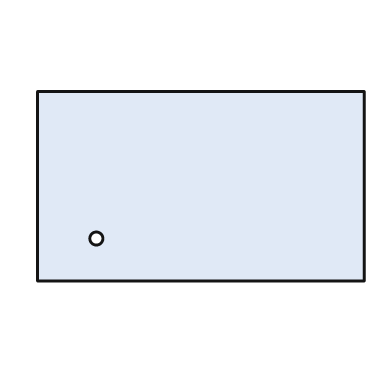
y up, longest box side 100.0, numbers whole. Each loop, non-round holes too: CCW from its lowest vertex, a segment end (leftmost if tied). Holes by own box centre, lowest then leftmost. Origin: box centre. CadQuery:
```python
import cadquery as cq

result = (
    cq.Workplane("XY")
    .moveTo(-50.0, -29.0)
    .lineTo(50.0, -29.0)
    .lineTo(50.0, 29.0)
    .lineTo(-50.0, 29.0)
    .close()
    .moveTo(-32.0, -16.0)
    .circle(2.0)
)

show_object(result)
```